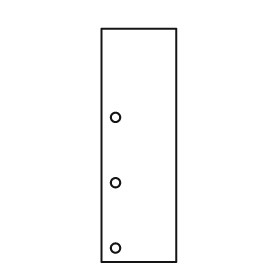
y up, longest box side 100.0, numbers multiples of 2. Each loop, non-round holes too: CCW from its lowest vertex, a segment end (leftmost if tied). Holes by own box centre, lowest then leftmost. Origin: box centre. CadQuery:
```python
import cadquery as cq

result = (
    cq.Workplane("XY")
    .moveTo(-16.0, -50.0)
    .lineTo(16.0, -50.0)
    .lineTo(16.0, 50.0)
    .lineTo(-16.0, 50.0)
    .close()
    .moveTo(-10.0, -44.0)
    .circle(2.0)
    .moveTo(-10.0, -16.0)
    .circle(2.0)
    .moveTo(-10.0, 12.0)
    .circle(2.0)
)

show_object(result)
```